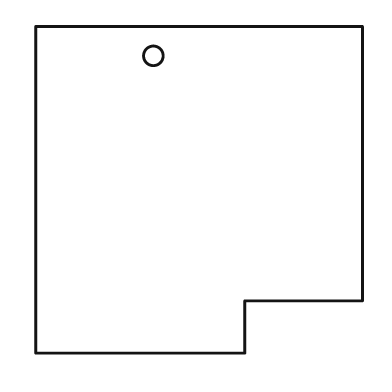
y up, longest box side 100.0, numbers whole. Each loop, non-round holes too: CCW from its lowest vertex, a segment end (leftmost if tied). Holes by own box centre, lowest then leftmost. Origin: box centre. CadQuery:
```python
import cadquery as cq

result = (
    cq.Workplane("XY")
    .moveTo(-50.0, -50.0)
    .lineTo(14.0, -50.0)
    .lineTo(14.0, -34.0)
    .lineTo(50.0, -34.0)
    .lineTo(50.0, 50.0)
    .lineTo(-50.0, 50.0)
    .close()
    .moveTo(-14.0, 41.0)
    .circle(3.0)
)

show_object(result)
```